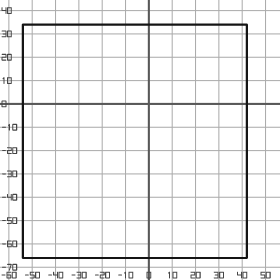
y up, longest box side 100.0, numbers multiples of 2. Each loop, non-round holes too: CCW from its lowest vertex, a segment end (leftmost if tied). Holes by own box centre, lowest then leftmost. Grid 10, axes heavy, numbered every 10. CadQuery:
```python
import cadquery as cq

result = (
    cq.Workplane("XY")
    .moveTo(-54.0, -66.0)
    .lineTo(42.0, -66.0)
    .lineTo(42.0, 34.0)
    .lineTo(-54.0, 34.0)
    .close()
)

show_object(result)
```